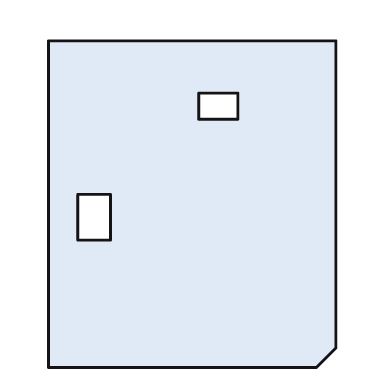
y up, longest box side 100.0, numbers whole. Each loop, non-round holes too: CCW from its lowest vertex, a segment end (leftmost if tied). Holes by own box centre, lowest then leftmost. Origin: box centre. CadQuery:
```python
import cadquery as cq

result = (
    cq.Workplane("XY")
    .moveTo(-44.0, -50.0)
    .lineTo(38.0, -50.0)
    .lineTo(44.0, -44.0)
    .lineTo(44.0, 50.0)
    .lineTo(-44.0, 50.0)
    .close()
    .moveTo(-35.0, -11.0)
    .lineTo(-25.0, -11.0)
    .lineTo(-25.0, 3.0)
    .lineTo(-35.0, 3.0)
    .close()
    .moveTo(2.0, 26.0)
    .lineTo(14.0, 26.0)
    .lineTo(14.0, 34.0)
    .lineTo(2.0, 34.0)
    .close()
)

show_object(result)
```